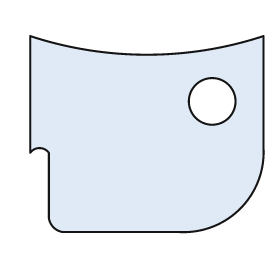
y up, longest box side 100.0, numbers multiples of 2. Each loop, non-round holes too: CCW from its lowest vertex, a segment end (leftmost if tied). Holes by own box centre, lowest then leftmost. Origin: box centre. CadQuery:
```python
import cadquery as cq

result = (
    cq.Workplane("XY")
    .moveTo(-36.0, -42.0)
    .lineTo(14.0, -42.0)
    .threePointArc((40.0, -32.0), (50.0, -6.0))
    .lineTo(50.0, 42.0)
    .threePointArc((0.0, 34.0), (-50.0, 42.0))
    .lineTo(-50.0, -8.0)
    .threePointArc((-46.0, -6.0), (-42.0, -8.0))
    .lineTo(-42.0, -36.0)
    .threePointArc((-40.0, -40.0), (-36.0, -42.0))
    .close()
    .moveTo(28.0, 14.0)
    .circle(10.0)
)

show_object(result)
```